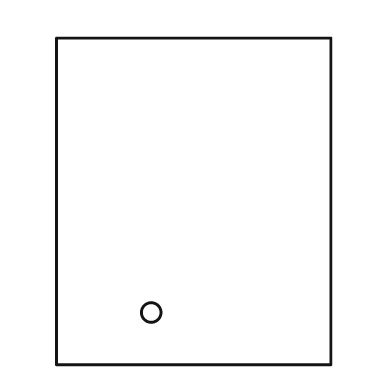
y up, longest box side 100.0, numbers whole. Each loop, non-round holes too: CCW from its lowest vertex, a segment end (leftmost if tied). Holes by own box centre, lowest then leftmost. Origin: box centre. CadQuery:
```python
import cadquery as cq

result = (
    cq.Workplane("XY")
    .moveTo(-42.0, -50.0)
    .lineTo(42.0, -50.0)
    .lineTo(42.0, 50.0)
    .lineTo(-42.0, 50.0)
    .close()
    .moveTo(-13.0, -34.0)
    .circle(3.0)
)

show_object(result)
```